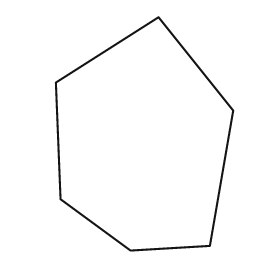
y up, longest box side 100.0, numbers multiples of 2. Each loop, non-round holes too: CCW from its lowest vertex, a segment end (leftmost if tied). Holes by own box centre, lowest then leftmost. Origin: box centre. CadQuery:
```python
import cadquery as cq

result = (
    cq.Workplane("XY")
    .moveTo(-6.0, -50.0)
    .lineTo(28.0, -48.0)
    .lineTo(38.0, 10.0)
    .lineTo(6.0, 50.0)
    .lineTo(-38.0, 22.0)
    .lineTo(-36.0, -28.0)
    .close()
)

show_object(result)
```